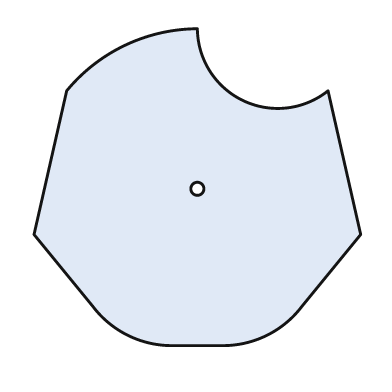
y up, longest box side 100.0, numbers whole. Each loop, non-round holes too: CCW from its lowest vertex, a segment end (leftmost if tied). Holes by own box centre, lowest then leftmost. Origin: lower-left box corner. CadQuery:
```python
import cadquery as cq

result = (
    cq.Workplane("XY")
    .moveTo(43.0, 0.0)
    .lineTo(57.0, 0.0)
    .threePointArc((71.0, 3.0), (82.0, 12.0))
    .lineTo(100.0, 34.0)
    .lineTo(90.0, 78.0)
    .threePointArc((64.0, 75.0), (50.0, 97.0))
    .threePointArc((28.0, 92.0), (10.0, 78.0))
    .lineTo(0.0, 34.0)
    .lineTo(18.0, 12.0)
    .threePointArc((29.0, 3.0), (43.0, 0.0))
    .close()
    .moveTo(50.0, 48.0)
    .circle(2.0)
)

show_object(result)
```